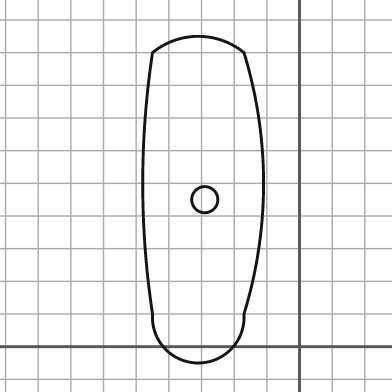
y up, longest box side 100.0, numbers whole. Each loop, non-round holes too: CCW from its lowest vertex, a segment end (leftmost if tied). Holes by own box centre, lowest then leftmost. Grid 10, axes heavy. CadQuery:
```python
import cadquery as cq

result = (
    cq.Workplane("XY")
    .moveTo(-45.0, 10.0)
    .threePointArc((-31.0, -5.0), (-17.0, 10.0))
    .threePointArc((-11.0, 50.0), (-17.0, 90.0))
    .threePointArc((-31.0, 95.0), (-45.0, 90.0))
    .threePointArc((-48.0, 50.0), (-45.0, 10.0))
    .close()
    .moveTo(-29.0, 45.0)
    .circle(4.0)
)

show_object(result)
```